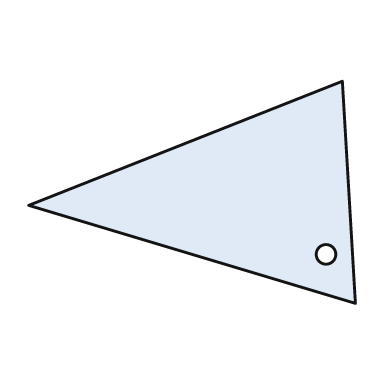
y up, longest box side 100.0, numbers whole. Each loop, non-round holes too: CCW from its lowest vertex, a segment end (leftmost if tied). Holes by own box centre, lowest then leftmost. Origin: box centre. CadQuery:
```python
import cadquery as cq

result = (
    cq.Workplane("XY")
    .moveTo(50.0, -34.0)
    .lineTo(46.0, 34.0)
    .lineTo(-50.0, -4.0)
    .close()
    .moveTo(41.0, -19.0)
    .circle(3.0)
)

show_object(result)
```